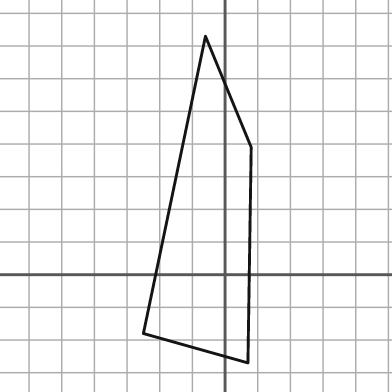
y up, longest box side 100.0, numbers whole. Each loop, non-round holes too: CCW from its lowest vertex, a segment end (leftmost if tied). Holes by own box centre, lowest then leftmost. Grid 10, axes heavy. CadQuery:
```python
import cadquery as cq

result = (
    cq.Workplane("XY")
    .moveTo(7.0, -27.0)
    .lineTo(8.0, 39.0)
    .lineTo(-6.0, 73.0)
    .lineTo(-25.0, -18.0)
    .close()
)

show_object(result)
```